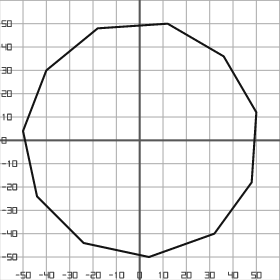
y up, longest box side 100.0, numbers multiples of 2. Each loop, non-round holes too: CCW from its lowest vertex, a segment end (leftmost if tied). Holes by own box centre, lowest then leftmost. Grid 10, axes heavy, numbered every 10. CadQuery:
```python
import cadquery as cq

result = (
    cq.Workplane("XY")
    .moveTo(4.0, -50.0)
    .lineTo(32.0, -40.0)
    .lineTo(48.0, -18.0)
    .lineTo(50.0, 12.0)
    .lineTo(36.0, 36.0)
    .lineTo(12.0, 50.0)
    .lineTo(-18.0, 48.0)
    .lineTo(-40.0, 30.0)
    .lineTo(-50.0, 4.0)
    .lineTo(-44.0, -24.0)
    .lineTo(-24.0, -44.0)
    .close()
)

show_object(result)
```